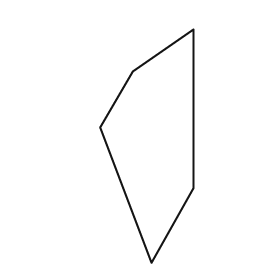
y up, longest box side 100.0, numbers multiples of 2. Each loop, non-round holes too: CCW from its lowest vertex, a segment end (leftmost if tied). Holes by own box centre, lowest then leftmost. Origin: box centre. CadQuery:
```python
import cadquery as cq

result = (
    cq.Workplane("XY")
    .moveTo(2.0, -50.0)
    .lineTo(20.0, -18.0)
    .lineTo(20.0, 50.0)
    .lineTo(-6.0, 32.0)
    .lineTo(-20.0, 8.0)
    .close()
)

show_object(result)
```